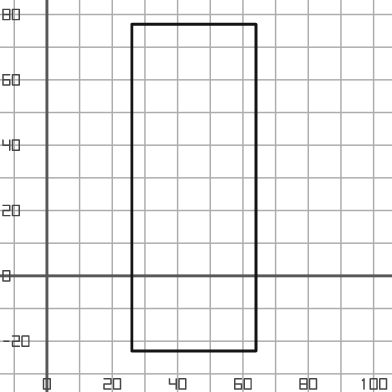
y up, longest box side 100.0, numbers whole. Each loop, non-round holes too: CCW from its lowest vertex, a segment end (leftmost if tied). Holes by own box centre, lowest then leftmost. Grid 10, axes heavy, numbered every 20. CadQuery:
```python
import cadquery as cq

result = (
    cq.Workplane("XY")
    .moveTo(26.0, -23.0)
    .lineTo(64.0, -23.0)
    .lineTo(64.0, 77.0)
    .lineTo(26.0, 77.0)
    .close()
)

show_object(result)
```